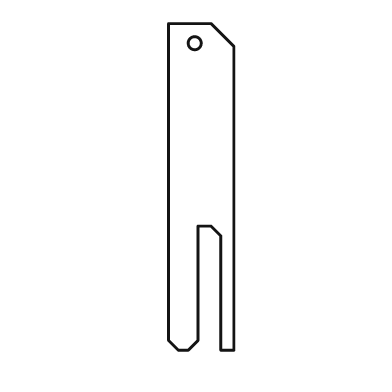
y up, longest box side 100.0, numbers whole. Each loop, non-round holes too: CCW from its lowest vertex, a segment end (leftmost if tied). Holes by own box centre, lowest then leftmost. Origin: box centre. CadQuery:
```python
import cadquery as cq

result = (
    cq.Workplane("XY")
    .moveTo(-7.0, -50.0)
    .lineTo(-4.0, -50.0)
    .lineTo(-1.0, -47.0)
    .lineTo(-1.0, -12.0)
    .lineTo(3.0, -12.0)
    .lineTo(6.0, -15.0)
    .lineTo(6.0, -50.0)
    .lineTo(10.0, -50.0)
    .lineTo(10.0, 43.0)
    .lineTo(3.0, 50.0)
    .lineTo(-10.0, 50.0)
    .lineTo(-10.0, -47.0)
    .close()
    .moveTo(-2.0, 44.0)
    .circle(2.0)
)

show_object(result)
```